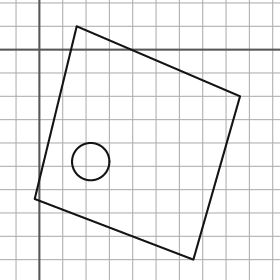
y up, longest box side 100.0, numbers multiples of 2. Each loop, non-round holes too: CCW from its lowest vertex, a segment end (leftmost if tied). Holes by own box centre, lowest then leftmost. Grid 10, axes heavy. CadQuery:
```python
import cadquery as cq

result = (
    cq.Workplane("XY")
    .moveTo(66.0, -90.0)
    .lineTo(86.0, -20.0)
    .lineTo(16.0, 10.0)
    .lineTo(-2.0, -64.0)
    .close()
    .moveTo(22.0, -48.0)
    .circle(8.0)
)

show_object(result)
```